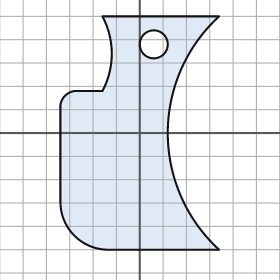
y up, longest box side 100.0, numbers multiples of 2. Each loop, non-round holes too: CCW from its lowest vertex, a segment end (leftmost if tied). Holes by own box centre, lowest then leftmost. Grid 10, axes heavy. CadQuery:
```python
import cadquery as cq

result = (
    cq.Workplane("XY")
    .moveTo(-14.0, -50.0)
    .lineTo(34.0, -50.0)
    .threePointArc((12.0, 0.0), (34.0, 50.0))
    .lineTo(-16.0, 50.0)
    .threePointArc((-12.0, 34.0), (-16.0, 18.0))
    .lineTo(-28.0, 18.0)
    .threePointArc((-32.0, 16.0), (-34.0, 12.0))
    .lineTo(-34.0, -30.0)
    .threePointArc((-28.0, -44.0), (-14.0, -50.0))
    .close()
    .moveTo(6.0, 38.0)
    .circle(6.0)
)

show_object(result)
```